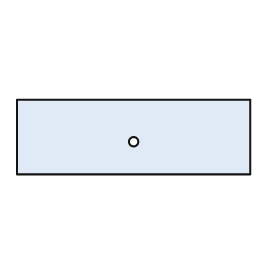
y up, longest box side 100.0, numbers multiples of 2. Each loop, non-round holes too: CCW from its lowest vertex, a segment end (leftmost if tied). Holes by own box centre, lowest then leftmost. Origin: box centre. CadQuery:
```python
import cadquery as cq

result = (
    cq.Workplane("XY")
    .moveTo(-50.0, -16.0)
    .lineTo(50.0, -16.0)
    .lineTo(50.0, 16.0)
    .lineTo(-50.0, 16.0)
    .close()
    .moveTo(0.0, -2.0)
    .circle(2.0)
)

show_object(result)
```